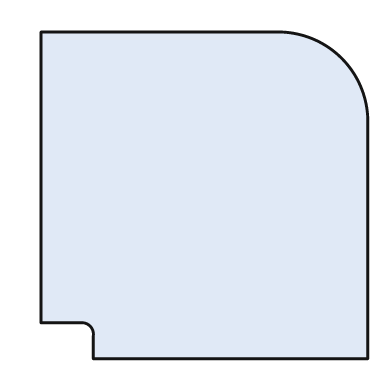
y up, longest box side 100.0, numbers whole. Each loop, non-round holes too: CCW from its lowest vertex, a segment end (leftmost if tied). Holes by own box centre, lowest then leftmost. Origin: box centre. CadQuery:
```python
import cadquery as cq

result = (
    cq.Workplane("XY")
    .moveTo(-34.0, -50.0)
    .lineTo(50.0, -50.0)
    .lineTo(50.0, 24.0)
    .threePointArc((42.0, 42.0), (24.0, 50.0))
    .lineTo(-50.0, 50.0)
    .lineTo(-50.0, -39.0)
    .lineTo(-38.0, -39.0)
    .threePointArc((-35.0, -40.0), (-34.0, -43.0))
    .close()
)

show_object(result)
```